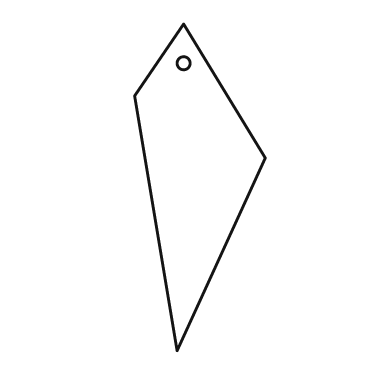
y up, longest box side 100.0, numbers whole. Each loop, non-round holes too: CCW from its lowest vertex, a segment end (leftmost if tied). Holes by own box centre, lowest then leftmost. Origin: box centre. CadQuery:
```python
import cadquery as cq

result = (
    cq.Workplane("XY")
    .moveTo(-7.0, -50.0)
    .lineTo(20.0, 9.0)
    .lineTo(-5.0, 50.0)
    .lineTo(-20.0, 28.0)
    .close()
    .moveTo(-5.0, 38.0)
    .circle(2.0)
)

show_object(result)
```